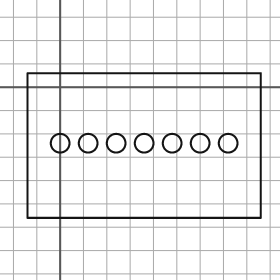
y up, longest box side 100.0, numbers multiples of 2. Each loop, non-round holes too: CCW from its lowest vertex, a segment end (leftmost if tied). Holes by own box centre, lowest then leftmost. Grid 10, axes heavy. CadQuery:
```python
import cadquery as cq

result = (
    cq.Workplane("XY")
    .moveTo(-14.0, -56.0)
    .lineTo(86.0, -56.0)
    .lineTo(86.0, 6.0)
    .lineTo(-14.0, 6.0)
    .close()
    .moveTo(0.0, -24.0)
    .circle(4.0)
    .moveTo(12.0, -24.0)
    .circle(4.0)
    .moveTo(24.0, -24.0)
    .circle(4.0)
    .moveTo(36.0, -24.0)
    .circle(4.0)
    .moveTo(48.0, -24.0)
    .circle(4.0)
    .moveTo(60.0, -24.0)
    .circle(4.0)
    .moveTo(72.0, -24.0)
    .circle(4.0)
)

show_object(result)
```